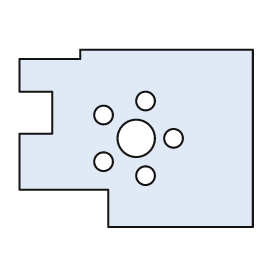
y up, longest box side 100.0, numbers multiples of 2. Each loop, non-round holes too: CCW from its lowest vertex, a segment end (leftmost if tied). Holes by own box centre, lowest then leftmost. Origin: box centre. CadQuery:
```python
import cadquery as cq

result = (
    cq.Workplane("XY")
    .moveTo(-12.0, -38.0)
    .lineTo(50.0, -38.0)
    .lineTo(50.0, 38.0)
    .lineTo(-24.0, 38.0)
    .lineTo(-24.0, 34.0)
    .lineTo(-50.0, 34.0)
    .lineTo(-50.0, 20.0)
    .lineTo(-36.0, 20.0)
    .lineTo(-36.0, 2.0)
    .lineTo(-50.0, 2.0)
    .lineTo(-50.0, -22.0)
    .lineTo(-12.0, -22.0)
    .close()
    .moveTo(4.0, -16.0)
    .circle(4.0)
    .moveTo(-14.0, -10.0)
    .circle(4.0)
    .moveTo(0.0, 0.0)
    .circle(8.0)
    .moveTo(16.0, 0.0)
    .circle(4.0)
    .moveTo(-14.0, 10.0)
    .circle(4.0)
    .moveTo(4.0, 16.0)
    .circle(4.0)
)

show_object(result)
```